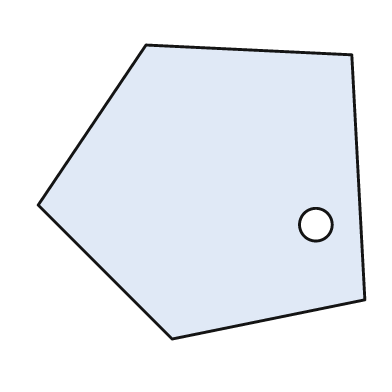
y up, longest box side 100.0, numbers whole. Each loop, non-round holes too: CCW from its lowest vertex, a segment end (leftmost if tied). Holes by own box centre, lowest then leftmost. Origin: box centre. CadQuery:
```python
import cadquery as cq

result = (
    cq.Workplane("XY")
    .moveTo(-9.0, -45.0)
    .lineTo(50.0, -33.0)
    .lineTo(46.0, 42.0)
    .lineTo(-17.0, 45.0)
    .lineTo(-50.0, -4.0)
    .close()
    .moveTo(35.0, -10.0)
    .circle(5.0)
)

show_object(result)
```